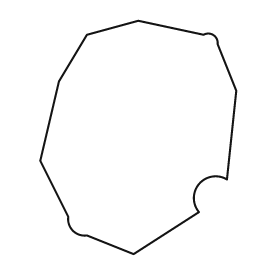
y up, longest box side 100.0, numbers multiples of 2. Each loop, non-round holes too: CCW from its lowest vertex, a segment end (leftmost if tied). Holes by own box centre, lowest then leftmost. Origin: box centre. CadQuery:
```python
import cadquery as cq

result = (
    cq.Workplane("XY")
    .moveTo(-2.0, -50.0)
    .lineTo(26.0, -32.0)
    .threePointArc((26.0, -20.0), (38.0, -18.0))
    .lineTo(42.0, 20.0)
    .lineTo(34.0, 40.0)
    .threePointArc((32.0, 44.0), (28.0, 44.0))
    .lineTo(0.0, 50.0)
    .lineTo(-22.0, 44.0)
    .lineTo(-34.0, 24.0)
    .lineTo(-42.0, -10.0)
    .lineTo(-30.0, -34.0)
    .threePointArc((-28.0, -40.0), (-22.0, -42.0))
    .close()
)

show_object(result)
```